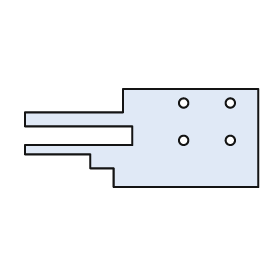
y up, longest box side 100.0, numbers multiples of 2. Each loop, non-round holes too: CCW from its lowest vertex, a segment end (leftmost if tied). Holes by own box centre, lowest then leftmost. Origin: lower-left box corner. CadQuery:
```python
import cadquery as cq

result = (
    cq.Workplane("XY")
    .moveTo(38.0, 0.0)
    .lineTo(100.0, 0.0)
    .lineTo(100.0, 42.0)
    .lineTo(42.0, 42.0)
    .lineTo(42.0, 32.0)
    .lineTo(0.0, 32.0)
    .lineTo(0.0, 26.0)
    .lineTo(46.0, 26.0)
    .lineTo(46.0, 18.0)
    .lineTo(0.0, 18.0)
    .lineTo(0.0, 14.0)
    .lineTo(28.0, 14.0)
    .lineTo(28.0, 8.0)
    .lineTo(38.0, 8.0)
    .close()
    .moveTo(68.0, 20.0)
    .circle(2.0)
    .moveTo(88.0, 20.0)
    .circle(2.0)
    .moveTo(68.0, 36.0)
    .circle(2.0)
    .moveTo(88.0, 36.0)
    .circle(2.0)
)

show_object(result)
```